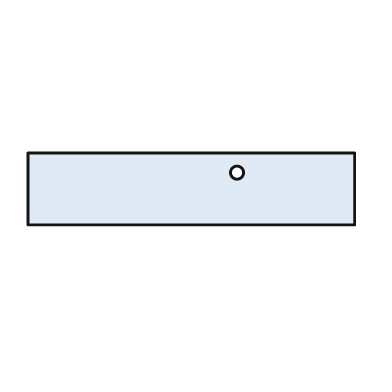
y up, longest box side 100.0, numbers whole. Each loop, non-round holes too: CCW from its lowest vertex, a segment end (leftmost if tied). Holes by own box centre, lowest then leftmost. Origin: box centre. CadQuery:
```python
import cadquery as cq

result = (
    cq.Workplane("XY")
    .moveTo(-50.0, -11.0)
    .lineTo(50.0, -11.0)
    .lineTo(50.0, 11.0)
    .lineTo(-50.0, 11.0)
    .close()
    .moveTo(14.0, 5.0)
    .circle(2.0)
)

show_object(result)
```